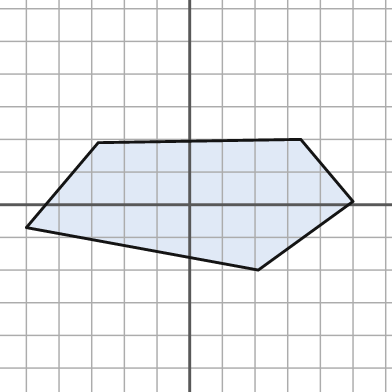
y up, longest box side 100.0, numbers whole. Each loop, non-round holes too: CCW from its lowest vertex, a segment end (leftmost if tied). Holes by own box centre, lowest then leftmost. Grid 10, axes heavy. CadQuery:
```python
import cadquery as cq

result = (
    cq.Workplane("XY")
    .moveTo(21.0, -20.0)
    .lineTo(50.0, 1.0)
    .lineTo(34.0, 20.0)
    .lineTo(-28.0, 19.0)
    .lineTo(-50.0, -7.0)
    .close()
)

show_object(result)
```